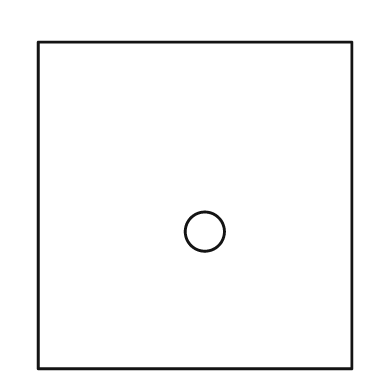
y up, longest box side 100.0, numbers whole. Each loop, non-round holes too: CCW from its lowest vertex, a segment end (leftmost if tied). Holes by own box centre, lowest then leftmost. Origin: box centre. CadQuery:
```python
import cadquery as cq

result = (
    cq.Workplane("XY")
    .moveTo(-48.0, -50.0)
    .lineTo(48.0, -50.0)
    .lineTo(48.0, 50.0)
    .lineTo(-48.0, 50.0)
    .close()
    .moveTo(3.0, -8.0)
    .circle(6.0)
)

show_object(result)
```